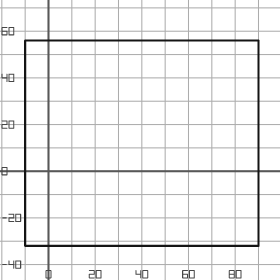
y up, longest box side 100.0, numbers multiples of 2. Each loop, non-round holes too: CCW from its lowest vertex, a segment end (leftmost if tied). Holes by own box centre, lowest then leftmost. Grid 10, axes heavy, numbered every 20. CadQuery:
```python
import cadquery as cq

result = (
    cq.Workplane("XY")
    .moveTo(-10.0, -32.0)
    .lineTo(90.0, -32.0)
    .lineTo(90.0, 56.0)
    .lineTo(-10.0, 56.0)
    .close()
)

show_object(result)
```